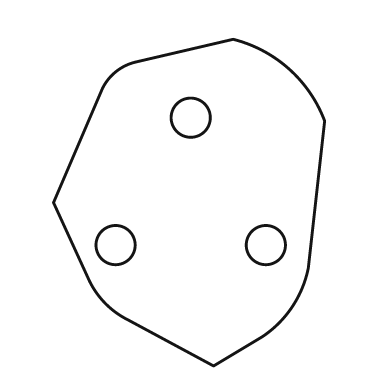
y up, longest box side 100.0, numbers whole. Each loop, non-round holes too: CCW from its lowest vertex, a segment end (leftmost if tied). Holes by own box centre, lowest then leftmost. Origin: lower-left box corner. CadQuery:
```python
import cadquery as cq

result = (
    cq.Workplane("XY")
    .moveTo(49.0, 0.0)
    .lineTo(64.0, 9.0)
    .threePointArc((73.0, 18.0), (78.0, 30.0))
    .lineTo(83.0, 75.0)
    .threePointArc((72.0, 91.0), (55.0, 100.0))
    .lineTo(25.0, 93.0)
    .threePointArc((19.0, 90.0), (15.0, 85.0))
    .lineTo(0.0, 50.0)
    .lineTo(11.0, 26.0)
    .threePointArc((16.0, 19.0), (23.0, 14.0))
    .close()
    .moveTo(19.0, 37.0)
    .circle(6.0)
    .moveTo(65.0, 37.0)
    .circle(6.0)
    .moveTo(42.0, 76.0)
    .circle(6.0)
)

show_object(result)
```